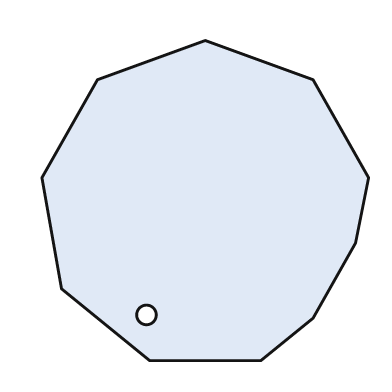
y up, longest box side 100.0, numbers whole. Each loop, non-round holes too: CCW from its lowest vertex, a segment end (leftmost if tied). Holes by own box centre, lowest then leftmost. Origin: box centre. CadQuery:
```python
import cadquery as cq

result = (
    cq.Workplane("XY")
    .moveTo(-17.0, -49.0)
    .lineTo(17.0, -49.0)
    .lineTo(33.0, -36.0)
    .lineTo(46.0, -13.0)
    .lineTo(50.0, 7.0)
    .lineTo(33.0, 37.0)
    .lineTo(0.0, 49.0)
    .lineTo(-33.0, 37.0)
    .lineTo(-50.0, 7.0)
    .lineTo(-44.0, -27.0)
    .close()
    .moveTo(-18.0, -35.0)
    .circle(3.0)
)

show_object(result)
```